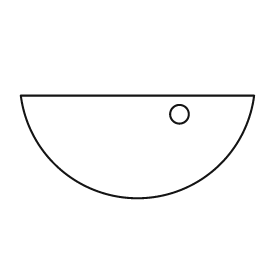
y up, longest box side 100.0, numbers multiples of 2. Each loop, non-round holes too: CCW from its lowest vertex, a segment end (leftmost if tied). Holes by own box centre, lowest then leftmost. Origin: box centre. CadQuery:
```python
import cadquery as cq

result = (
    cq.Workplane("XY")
    .moveTo(-50.0, 22.0)
    .threePointArc((0.0, -22.0), (50.0, 22.0))
    .close()
    .moveTo(18.0, 14.0)
    .circle(4.0)
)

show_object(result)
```